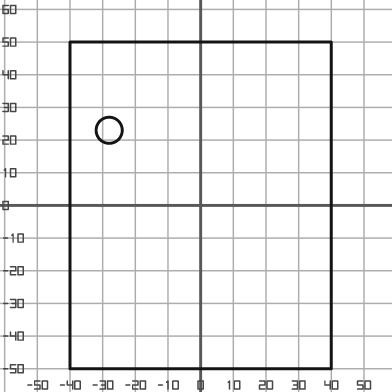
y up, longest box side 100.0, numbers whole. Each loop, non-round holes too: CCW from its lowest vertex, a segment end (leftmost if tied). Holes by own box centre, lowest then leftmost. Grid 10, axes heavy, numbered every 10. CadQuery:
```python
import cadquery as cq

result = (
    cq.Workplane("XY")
    .moveTo(-40.0, -50.0)
    .lineTo(40.0, -50.0)
    .lineTo(40.0, 50.0)
    .lineTo(-40.0, 50.0)
    .close()
    .moveTo(-28.0, 23.0)
    .circle(4.0)
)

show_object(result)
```